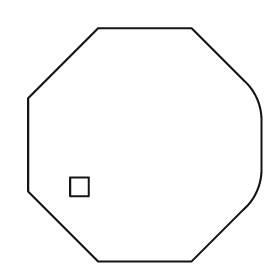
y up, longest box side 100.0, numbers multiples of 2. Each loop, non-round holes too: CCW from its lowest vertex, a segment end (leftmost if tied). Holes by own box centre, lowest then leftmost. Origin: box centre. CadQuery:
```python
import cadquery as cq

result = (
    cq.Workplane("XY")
    .moveTo(-20.0, -50.0)
    .lineTo(20.0, -50.0)
    .lineTo(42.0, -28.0)
    .threePointArc((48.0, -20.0), (50.0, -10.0))
    .lineTo(50.0, 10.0)
    .threePointArc((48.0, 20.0), (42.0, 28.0))
    .lineTo(20.0, 50.0)
    .lineTo(-20.0, 50.0)
    .lineTo(-50.0, 20.0)
    .lineTo(-50.0, -20.0)
    .close()
    .moveTo(-32.0, -22.0)
    .lineTo(-24.0, -22.0)
    .lineTo(-24.0, -14.0)
    .lineTo(-32.0, -14.0)
    .close()
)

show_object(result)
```